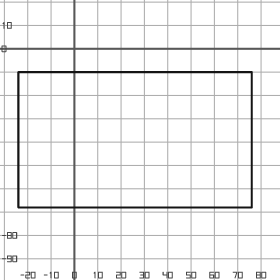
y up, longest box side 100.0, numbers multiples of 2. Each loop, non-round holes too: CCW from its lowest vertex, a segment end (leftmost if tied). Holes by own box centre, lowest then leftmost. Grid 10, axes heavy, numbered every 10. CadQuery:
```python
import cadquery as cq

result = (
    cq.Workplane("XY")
    .moveTo(-24.0, -68.0)
    .lineTo(76.0, -68.0)
    .lineTo(76.0, -10.0)
    .lineTo(-24.0, -10.0)
    .close()
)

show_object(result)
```